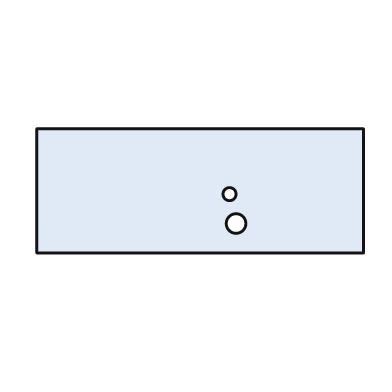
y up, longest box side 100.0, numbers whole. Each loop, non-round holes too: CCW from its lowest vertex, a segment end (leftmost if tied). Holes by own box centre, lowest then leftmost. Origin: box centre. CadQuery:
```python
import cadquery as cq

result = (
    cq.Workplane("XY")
    .moveTo(-50.0, -19.0)
    .lineTo(50.0, -19.0)
    .lineTo(50.0, 19.0)
    .lineTo(-50.0, 19.0)
    .close()
    .moveTo(11.0, -10.0)
    .circle(3.0)
    .moveTo(9.0, -1.0)
    .circle(2.0)
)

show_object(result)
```